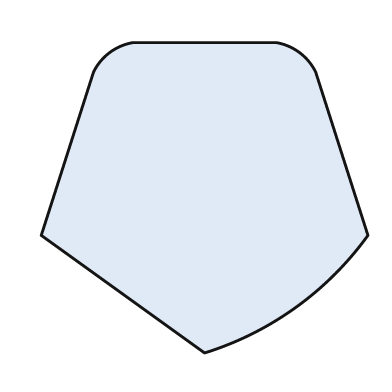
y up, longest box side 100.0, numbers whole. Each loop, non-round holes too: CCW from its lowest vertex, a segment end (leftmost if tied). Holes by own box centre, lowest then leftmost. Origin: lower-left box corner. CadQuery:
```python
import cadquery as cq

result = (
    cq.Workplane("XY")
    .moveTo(50.0, 0.0)
    .threePointArc((78.0, 14.0), (100.0, 36.0))
    .lineTo(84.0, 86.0)
    .threePointArc((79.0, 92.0), (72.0, 95.0))
    .lineTo(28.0, 95.0)
    .threePointArc((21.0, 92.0), (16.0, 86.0))
    .lineTo(0.0, 36.0)
    .close()
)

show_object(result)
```